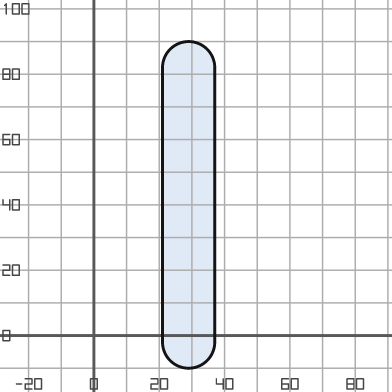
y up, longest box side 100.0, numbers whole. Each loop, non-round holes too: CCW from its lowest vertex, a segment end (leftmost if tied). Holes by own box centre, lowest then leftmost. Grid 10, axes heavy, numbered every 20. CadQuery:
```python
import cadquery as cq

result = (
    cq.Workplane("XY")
    .moveTo(21.0, -2.0)
    .threePointArc((29.0, -10.0), (37.0, -2.0))
    .lineTo(37.0, 82.0)
    .threePointArc((29.0, 90.0), (21.0, 82.0))
    .close()
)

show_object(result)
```